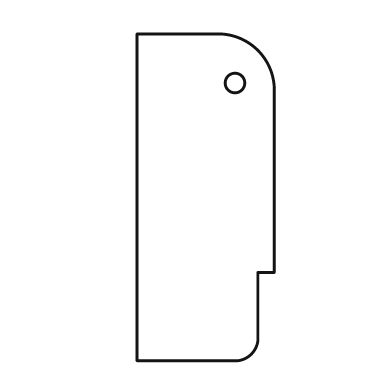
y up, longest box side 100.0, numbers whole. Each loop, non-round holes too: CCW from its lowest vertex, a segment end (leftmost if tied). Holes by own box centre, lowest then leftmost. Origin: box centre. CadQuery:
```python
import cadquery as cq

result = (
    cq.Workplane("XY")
    .moveTo(-21.0, -50.0)
    .lineTo(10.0, -50.0)
    .threePointArc((14.0, -48.0), (16.0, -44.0))
    .lineTo(16.0, -23.0)
    .lineTo(21.0, -23.0)
    .lineTo(21.0, 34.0)
    .threePointArc((16.0, 45.0), (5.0, 50.0))
    .lineTo(-21.0, 50.0)
    .close()
    .moveTo(9.0, 35.0)
    .circle(3.0)
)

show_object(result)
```